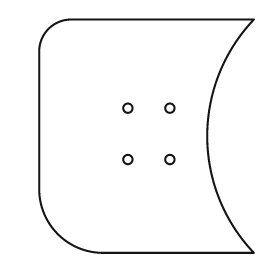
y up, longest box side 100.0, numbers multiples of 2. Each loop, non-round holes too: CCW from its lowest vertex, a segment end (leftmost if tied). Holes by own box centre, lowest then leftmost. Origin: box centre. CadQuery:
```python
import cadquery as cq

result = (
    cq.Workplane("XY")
    .moveTo(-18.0, -50.0)
    .lineTo(46.0, -50.0)
    .threePointArc((26.0, 0.0), (46.0, 50.0))
    .lineTo(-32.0, 50.0)
    .threePointArc((-42.0, 46.0), (-46.0, 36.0))
    .lineTo(-46.0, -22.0)
    .threePointArc((-38.0, -42.0), (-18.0, -50.0))
    .close()
    .moveTo(-8.0, -10.0)
    .circle(2.0)
    .moveTo(10.0, -10.0)
    .circle(2.0)
    .moveTo(-8.0, 12.0)
    .circle(2.0)
    .moveTo(10.0, 12.0)
    .circle(2.0)
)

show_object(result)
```